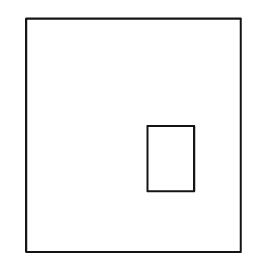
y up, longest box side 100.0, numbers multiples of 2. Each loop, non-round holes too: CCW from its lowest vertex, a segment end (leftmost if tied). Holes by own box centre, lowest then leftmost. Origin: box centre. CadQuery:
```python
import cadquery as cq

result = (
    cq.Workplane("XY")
    .moveTo(-46.0, -50.0)
    .lineTo(46.0, -50.0)
    .lineTo(46.0, 50.0)
    .lineTo(-46.0, 50.0)
    .close()
    .moveTo(6.0, -24.0)
    .lineTo(26.0, -24.0)
    .lineTo(26.0, 4.0)
    .lineTo(6.0, 4.0)
    .close()
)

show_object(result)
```